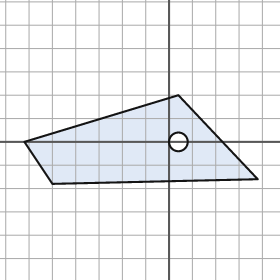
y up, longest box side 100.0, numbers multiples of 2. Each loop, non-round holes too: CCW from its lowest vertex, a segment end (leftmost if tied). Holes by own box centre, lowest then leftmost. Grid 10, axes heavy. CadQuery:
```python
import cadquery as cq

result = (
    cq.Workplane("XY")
    .moveTo(-50.0, -18.0)
    .lineTo(38.0, -16.0)
    .lineTo(4.0, 20.0)
    .lineTo(-62.0, 0.0)
    .close()
    .moveTo(4.0, 0.0)
    .circle(4.0)
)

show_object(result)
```